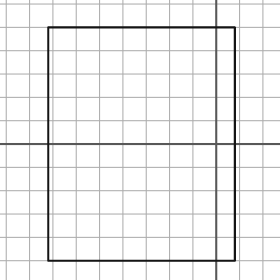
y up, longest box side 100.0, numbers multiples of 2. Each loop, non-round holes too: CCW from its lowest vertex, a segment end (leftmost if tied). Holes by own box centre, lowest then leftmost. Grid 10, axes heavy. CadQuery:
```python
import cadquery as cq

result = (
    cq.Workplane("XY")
    .moveTo(-72.0, -50.0)
    .lineTo(8.0, -50.0)
    .lineTo(8.0, 50.0)
    .lineTo(-72.0, 50.0)
    .close()
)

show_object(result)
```